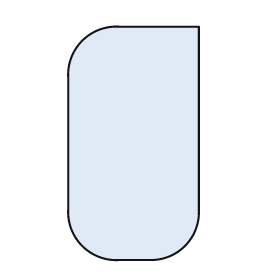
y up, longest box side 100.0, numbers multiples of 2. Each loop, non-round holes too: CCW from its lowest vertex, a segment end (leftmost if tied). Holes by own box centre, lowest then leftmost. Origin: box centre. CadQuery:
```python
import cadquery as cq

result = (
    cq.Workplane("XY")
    .moveTo(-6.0, -50.0)
    .lineTo(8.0, -50.0)
    .threePointArc((22.0, -44.0), (28.0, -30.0))
    .lineTo(28.0, 50.0)
    .lineTo(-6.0, 50.0)
    .threePointArc((-22.0, 44.0), (-28.0, 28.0))
    .lineTo(-28.0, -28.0)
    .threePointArc((-22.0, -44.0), (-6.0, -50.0))
    .close()
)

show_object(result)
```